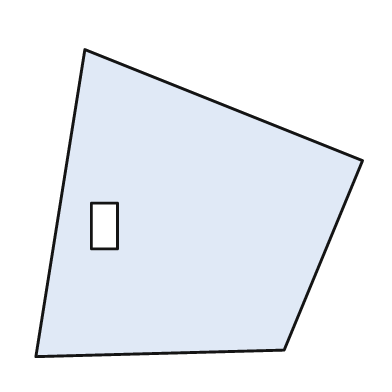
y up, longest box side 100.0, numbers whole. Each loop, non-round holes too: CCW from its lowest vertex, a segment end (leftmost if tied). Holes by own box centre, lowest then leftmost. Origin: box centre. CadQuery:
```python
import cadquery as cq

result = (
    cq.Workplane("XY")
    .moveTo(-50.0, -47.0)
    .lineTo(26.0, -45.0)
    .lineTo(50.0, 13.0)
    .lineTo(-35.0, 47.0)
    .close()
    .moveTo(-33.0, -14.0)
    .lineTo(-25.0, -14.0)
    .lineTo(-25.0, 0.0)
    .lineTo(-33.0, 0.0)
    .close()
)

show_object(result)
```